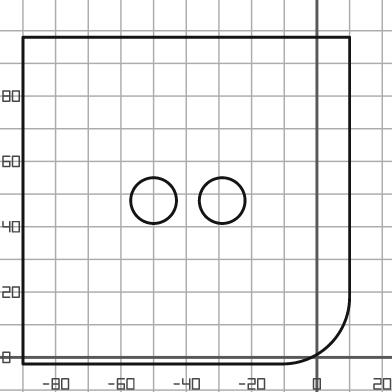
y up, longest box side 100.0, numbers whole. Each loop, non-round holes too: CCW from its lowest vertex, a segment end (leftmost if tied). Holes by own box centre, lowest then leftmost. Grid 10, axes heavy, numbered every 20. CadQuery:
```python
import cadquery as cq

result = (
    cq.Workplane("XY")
    .moveTo(-90.0, -2.0)
    .lineTo(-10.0, -2.0)
    .threePointArc((4.0, 4.0), (10.0, 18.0))
    .lineTo(10.0, 98.0)
    .lineTo(-90.0, 98.0)
    .close()
    .moveTo(-50.0, 48.0)
    .circle(7.0)
    .moveTo(-29.0, 48.0)
    .circle(7.0)
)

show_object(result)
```